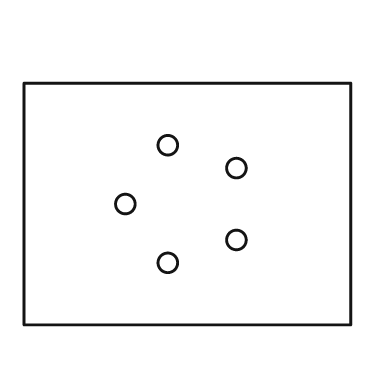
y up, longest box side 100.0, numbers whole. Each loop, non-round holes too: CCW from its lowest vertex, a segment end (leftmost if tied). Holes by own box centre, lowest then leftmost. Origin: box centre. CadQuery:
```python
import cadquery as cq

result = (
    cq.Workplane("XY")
    .moveTo(-50.0, -37.0)
    .lineTo(50.0, -37.0)
    .lineTo(50.0, 37.0)
    .lineTo(-50.0, 37.0)
    .close()
    .moveTo(-6.0, -18.0)
    .circle(3.0)
    .moveTo(15.0, -11.0)
    .circle(3.0)
    .moveTo(-19.0, 0.0)
    .circle(3.0)
    .moveTo(15.0, 11.0)
    .circle(3.0)
    .moveTo(-6.0, 18.0)
    .circle(3.0)
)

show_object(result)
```